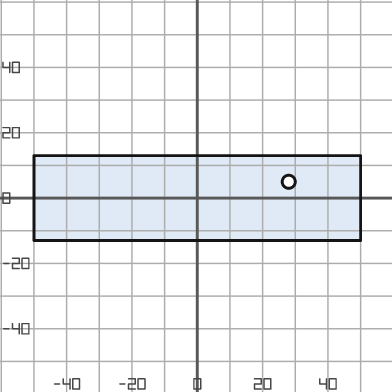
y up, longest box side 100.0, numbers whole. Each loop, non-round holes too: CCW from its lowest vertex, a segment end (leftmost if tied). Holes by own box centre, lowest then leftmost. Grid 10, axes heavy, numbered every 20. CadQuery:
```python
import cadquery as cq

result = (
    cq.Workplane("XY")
    .moveTo(-50.0, -13.0)
    .lineTo(50.0, -13.0)
    .lineTo(50.0, 13.0)
    .lineTo(-50.0, 13.0)
    .close()
    .moveTo(28.0, 5.0)
    .circle(2.0)
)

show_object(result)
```